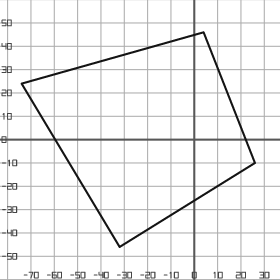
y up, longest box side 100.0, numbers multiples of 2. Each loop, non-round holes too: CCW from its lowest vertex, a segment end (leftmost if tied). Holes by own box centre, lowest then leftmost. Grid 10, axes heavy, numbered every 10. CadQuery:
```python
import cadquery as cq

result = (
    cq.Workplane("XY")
    .moveTo(-32.0, -46.0)
    .lineTo(26.0, -10.0)
    .lineTo(4.0, 46.0)
    .lineTo(-74.0, 24.0)
    .close()
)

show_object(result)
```